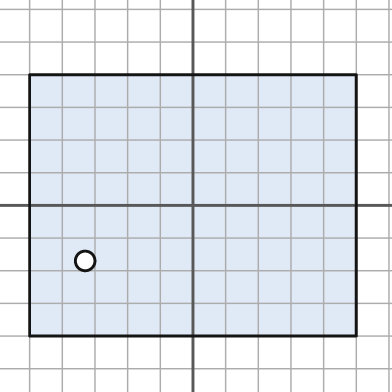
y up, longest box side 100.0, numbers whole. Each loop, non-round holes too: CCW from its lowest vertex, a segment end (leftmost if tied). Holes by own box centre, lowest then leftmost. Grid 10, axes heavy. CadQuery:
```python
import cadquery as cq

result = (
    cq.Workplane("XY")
    .moveTo(-50.0, -40.0)
    .lineTo(50.0, -40.0)
    .lineTo(50.0, 40.0)
    .lineTo(-50.0, 40.0)
    .close()
    .moveTo(-33.0, -17.0)
    .circle(3.0)
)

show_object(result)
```